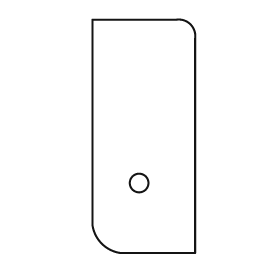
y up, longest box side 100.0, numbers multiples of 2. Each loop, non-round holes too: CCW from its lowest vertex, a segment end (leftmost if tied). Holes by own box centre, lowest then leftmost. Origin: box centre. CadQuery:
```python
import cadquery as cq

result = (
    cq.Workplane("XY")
    .moveTo(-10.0, -50.0)
    .lineTo(22.0, -50.0)
    .lineTo(22.0, 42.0)
    .threePointArc((20.0, 48.0), (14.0, 50.0))
    .lineTo(-22.0, 50.0)
    .lineTo(-22.0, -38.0)
    .threePointArc((-18.0, -46.0), (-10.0, -50.0))
    .close()
    .moveTo(-2.0, -20.0)
    .circle(4.0)
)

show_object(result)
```